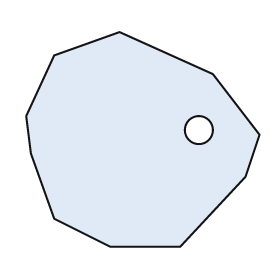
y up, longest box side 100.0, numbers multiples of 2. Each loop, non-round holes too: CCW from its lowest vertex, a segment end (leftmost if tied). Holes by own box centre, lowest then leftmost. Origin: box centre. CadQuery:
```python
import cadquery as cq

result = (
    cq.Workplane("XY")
    .moveTo(-14.0, -46.0)
    .lineTo(16.0, -46.0)
    .lineTo(44.0, -16.0)
    .lineTo(50.0, 2.0)
    .lineTo(30.0, 28.0)
    .lineTo(-10.0, 46.0)
    .lineTo(-38.0, 36.0)
    .lineTo(-50.0, 10.0)
    .lineTo(-48.0, -6.0)
    .lineTo(-38.0, -34.0)
    .close()
    .moveTo(24.0, 4.0)
    .circle(6.0)
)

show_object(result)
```